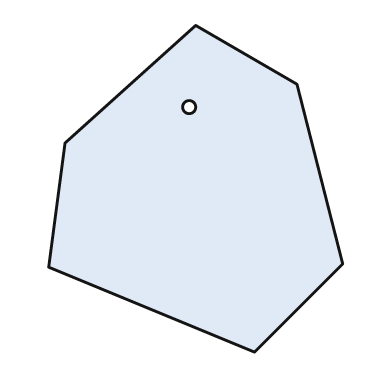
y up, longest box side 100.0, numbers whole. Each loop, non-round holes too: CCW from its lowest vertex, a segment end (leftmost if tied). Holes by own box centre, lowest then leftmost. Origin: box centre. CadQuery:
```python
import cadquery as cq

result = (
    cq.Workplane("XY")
    .moveTo(18.0, -50.0)
    .lineTo(45.0, -23.0)
    .lineTo(31.0, 32.0)
    .lineTo(0.0, 50.0)
    .lineTo(-40.0, 14.0)
    .lineTo(-45.0, -24.0)
    .close()
    .moveTo(-2.0, 25.0)
    .circle(2.0)
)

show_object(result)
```